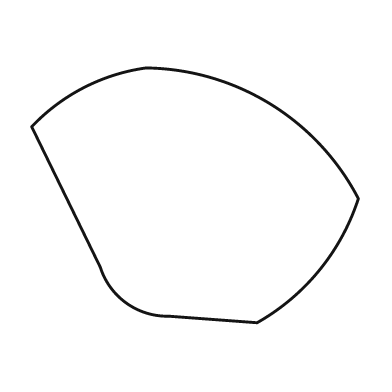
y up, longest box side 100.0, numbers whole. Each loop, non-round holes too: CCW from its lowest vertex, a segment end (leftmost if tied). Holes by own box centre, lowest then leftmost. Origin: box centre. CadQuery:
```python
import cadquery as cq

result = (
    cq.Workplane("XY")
    .moveTo(19.0, -39.0)
    .threePointArc((38.0, -23.0), (50.0, -1.0))
    .threePointArc((23.0, 28.0), (-15.0, 39.0))
    .threePointArc((-34.0, 33.0), (-50.0, 21.0))
    .lineTo(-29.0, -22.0)
    .threePointArc((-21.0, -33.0), (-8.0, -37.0))
    .close()
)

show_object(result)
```